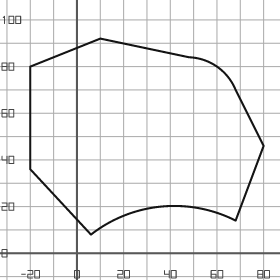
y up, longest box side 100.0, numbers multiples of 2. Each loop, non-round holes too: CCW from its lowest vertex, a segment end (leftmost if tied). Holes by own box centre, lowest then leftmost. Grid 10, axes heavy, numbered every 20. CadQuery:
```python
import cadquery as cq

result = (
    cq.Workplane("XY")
    .moveTo(6.0, 8.0)
    .threePointArc((36.0, 20.0), (68.0, 14.0))
    .lineTo(80.0, 46.0)
    .lineTo(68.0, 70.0)
    .threePointArc((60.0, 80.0), (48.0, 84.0))
    .lineTo(10.0, 92.0)
    .lineTo(-20.0, 80.0)
    .lineTo(-20.0, 36.0)
    .close()
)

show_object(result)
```